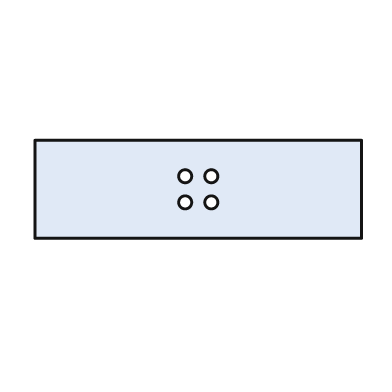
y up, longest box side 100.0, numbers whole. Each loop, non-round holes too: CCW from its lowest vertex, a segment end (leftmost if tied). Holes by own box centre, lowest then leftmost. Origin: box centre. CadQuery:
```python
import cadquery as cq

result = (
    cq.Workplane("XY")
    .moveTo(-50.0, -15.0)
    .lineTo(50.0, -15.0)
    .lineTo(50.0, 15.0)
    .lineTo(-50.0, 15.0)
    .close()
    .moveTo(-4.0, -4.0)
    .circle(2.0)
    .moveTo(4.0, -4.0)
    .circle(2.0)
    .moveTo(-4.0, 4.0)
    .circle(2.0)
    .moveTo(4.0, 4.0)
    .circle(2.0)
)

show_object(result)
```